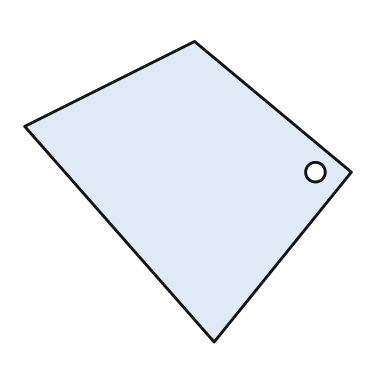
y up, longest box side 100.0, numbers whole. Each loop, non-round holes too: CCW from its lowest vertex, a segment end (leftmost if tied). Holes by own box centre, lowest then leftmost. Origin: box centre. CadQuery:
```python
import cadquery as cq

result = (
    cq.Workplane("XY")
    .moveTo(8.0, -46.0)
    .lineTo(50.0, 6.0)
    .lineTo(2.0, 46.0)
    .lineTo(-50.0, 20.0)
    .close()
    .moveTo(39.0, 6.0)
    .circle(3.0)
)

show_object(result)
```